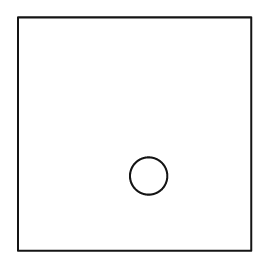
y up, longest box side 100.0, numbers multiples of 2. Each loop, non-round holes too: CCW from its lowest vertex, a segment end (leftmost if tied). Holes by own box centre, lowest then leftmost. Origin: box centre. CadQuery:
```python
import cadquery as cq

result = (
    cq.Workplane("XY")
    .moveTo(-50.0, -50.0)
    .lineTo(50.0, -50.0)
    .lineTo(50.0, 50.0)
    .lineTo(-50.0, 50.0)
    .close()
    .moveTo(6.0, -18.0)
    .circle(8.0)
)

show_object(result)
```